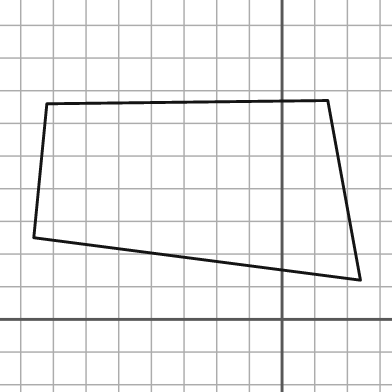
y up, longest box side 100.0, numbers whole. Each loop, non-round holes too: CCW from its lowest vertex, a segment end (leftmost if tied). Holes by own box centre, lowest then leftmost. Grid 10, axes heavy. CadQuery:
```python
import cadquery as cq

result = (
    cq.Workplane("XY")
    .moveTo(24.0, 12.0)
    .lineTo(14.0, 67.0)
    .lineTo(-72.0, 66.0)
    .lineTo(-76.0, 25.0)
    .close()
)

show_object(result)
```